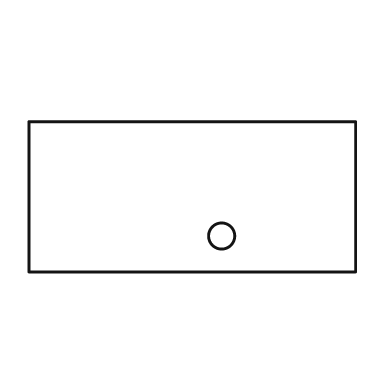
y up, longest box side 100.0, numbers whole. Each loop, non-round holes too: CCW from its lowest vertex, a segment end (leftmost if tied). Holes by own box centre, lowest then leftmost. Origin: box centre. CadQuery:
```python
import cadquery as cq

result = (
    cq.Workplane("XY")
    .moveTo(-50.0, -23.0)
    .lineTo(50.0, -23.0)
    .lineTo(50.0, 23.0)
    .lineTo(-50.0, 23.0)
    .close()
    .moveTo(9.0, -12.0)
    .circle(4.0)
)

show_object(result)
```